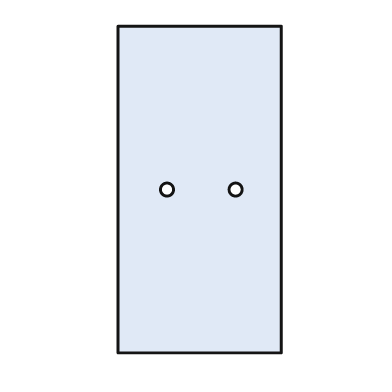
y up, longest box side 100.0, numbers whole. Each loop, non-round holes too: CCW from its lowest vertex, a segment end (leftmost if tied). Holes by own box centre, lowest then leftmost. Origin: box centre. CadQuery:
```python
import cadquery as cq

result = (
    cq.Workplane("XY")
    .moveTo(-25.0, -50.0)
    .lineTo(25.0, -50.0)
    .lineTo(25.0, 50.0)
    .lineTo(-25.0, 50.0)
    .close()
    .moveTo(-10.0, 0.0)
    .circle(2.0)
    .moveTo(11.0, 0.0)
    .circle(2.0)
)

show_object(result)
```